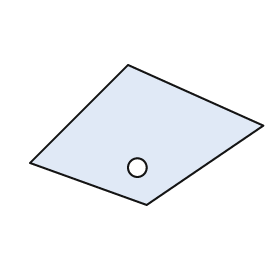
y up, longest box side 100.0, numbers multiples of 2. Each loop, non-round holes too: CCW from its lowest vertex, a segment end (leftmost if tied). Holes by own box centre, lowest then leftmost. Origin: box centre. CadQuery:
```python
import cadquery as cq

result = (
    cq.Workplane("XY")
    .moveTo(0.0, -30.0)
    .lineTo(50.0, 4.0)
    .lineTo(-8.0, 30.0)
    .lineTo(-50.0, -12.0)
    .close()
    .moveTo(-4.0, -14.0)
    .circle(4.0)
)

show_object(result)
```